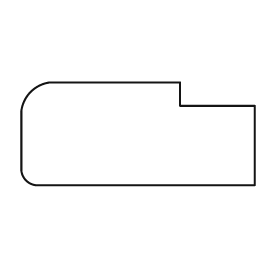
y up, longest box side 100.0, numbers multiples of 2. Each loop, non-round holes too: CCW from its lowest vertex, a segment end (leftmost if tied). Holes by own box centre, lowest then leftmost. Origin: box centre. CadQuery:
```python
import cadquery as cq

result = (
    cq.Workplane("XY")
    .moveTo(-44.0, -22.0)
    .lineTo(50.0, -22.0)
    .lineTo(50.0, 12.0)
    .lineTo(18.0, 12.0)
    .lineTo(18.0, 22.0)
    .lineTo(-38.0, 22.0)
    .threePointArc((-46.0, 18.0), (-50.0, 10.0))
    .lineTo(-50.0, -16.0)
    .threePointArc((-48.0, -20.0), (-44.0, -22.0))
    .close()
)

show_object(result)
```